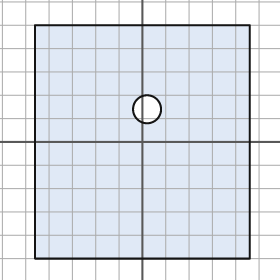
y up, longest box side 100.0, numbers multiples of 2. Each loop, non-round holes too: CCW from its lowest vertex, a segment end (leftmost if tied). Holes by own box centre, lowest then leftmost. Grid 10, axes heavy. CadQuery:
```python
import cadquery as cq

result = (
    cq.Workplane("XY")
    .moveTo(-46.0, -50.0)
    .lineTo(46.0, -50.0)
    .lineTo(46.0, 50.0)
    .lineTo(-46.0, 50.0)
    .close()
    .moveTo(2.0, 14.0)
    .circle(6.0)
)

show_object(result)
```